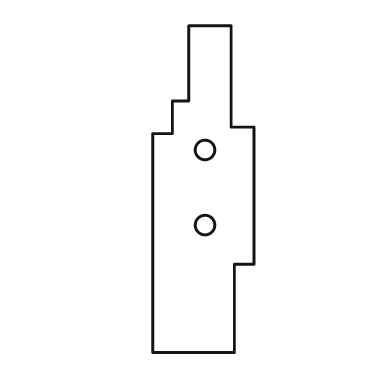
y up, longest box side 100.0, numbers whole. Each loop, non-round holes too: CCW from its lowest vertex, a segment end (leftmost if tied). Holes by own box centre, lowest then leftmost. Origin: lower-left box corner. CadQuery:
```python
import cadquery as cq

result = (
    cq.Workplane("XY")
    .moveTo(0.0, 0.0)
    .lineTo(25.0, 0.0)
    .lineTo(25.0, 27.0)
    .lineTo(31.0, 27.0)
    .lineTo(31.0, 69.0)
    .lineTo(24.0, 69.0)
    .lineTo(24.0, 100.0)
    .lineTo(11.0, 100.0)
    .lineTo(11.0, 77.0)
    .lineTo(6.0, 77.0)
    .lineTo(6.0, 67.0)
    .lineTo(0.0, 67.0)
    .close()
    .moveTo(16.0, 39.0)
    .circle(3.0)
    .moveTo(16.0, 62.0)
    .circle(3.0)
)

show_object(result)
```